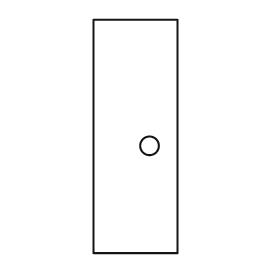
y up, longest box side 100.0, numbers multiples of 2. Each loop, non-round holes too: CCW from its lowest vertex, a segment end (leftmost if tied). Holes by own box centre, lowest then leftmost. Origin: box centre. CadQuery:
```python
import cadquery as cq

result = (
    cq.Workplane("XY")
    .moveTo(-18.0, -50.0)
    .lineTo(18.0, -50.0)
    .lineTo(18.0, 50.0)
    .lineTo(-18.0, 50.0)
    .close()
    .moveTo(6.0, -4.0)
    .circle(4.0)
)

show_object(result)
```